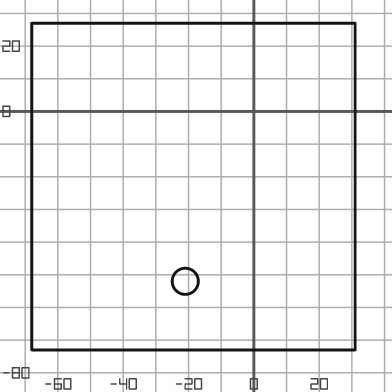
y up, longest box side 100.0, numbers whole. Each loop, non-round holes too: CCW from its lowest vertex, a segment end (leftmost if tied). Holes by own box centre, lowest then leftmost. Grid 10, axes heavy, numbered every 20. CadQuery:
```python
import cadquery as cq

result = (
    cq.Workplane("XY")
    .moveTo(-68.0, -73.0)
    .lineTo(31.0, -73.0)
    .lineTo(31.0, 27.0)
    .lineTo(-68.0, 27.0)
    .close()
    .moveTo(-21.0, -52.0)
    .circle(4.0)
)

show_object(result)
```